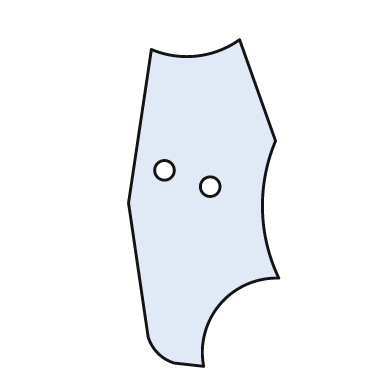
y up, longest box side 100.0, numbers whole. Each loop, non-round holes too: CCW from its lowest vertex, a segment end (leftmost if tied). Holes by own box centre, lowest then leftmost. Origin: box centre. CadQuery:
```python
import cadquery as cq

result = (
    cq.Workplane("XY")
    .moveTo(0.0, -50.0)
    .threePointArc((5.0, -31.0), (23.0, -23.0))
    .threePointArc((18.0, -2.0), (22.0, 19.0))
    .lineTo(11.0, 50.0)
    .threePointArc((-2.0, 45.0), (-16.0, 47.0))
    .lineTo(-23.0, 0.0)
    .lineTo(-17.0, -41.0)
    .threePointArc((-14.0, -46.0), (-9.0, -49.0))
    .close()
    .moveTo(2.0, 5.0)
    .circle(3.0)
    .moveTo(-12.0, 10.0)
    .circle(3.0)
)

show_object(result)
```